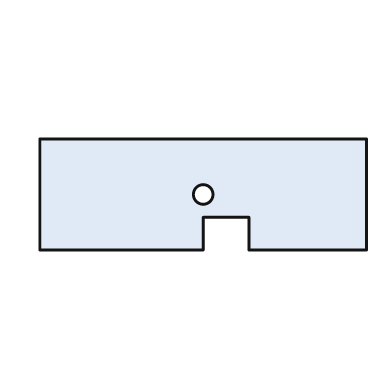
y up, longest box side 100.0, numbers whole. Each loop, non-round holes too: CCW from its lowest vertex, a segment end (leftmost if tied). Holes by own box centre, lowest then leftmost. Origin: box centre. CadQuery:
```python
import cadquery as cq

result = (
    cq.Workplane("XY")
    .moveTo(-50.0, -17.0)
    .lineTo(0.0, -17.0)
    .lineTo(0.0, -7.0)
    .lineTo(14.0, -7.0)
    .lineTo(14.0, -17.0)
    .lineTo(50.0, -17.0)
    .lineTo(50.0, 17.0)
    .lineTo(-50.0, 17.0)
    .close()
    .moveTo(0.0, 0.0)
    .circle(3.0)
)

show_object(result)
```